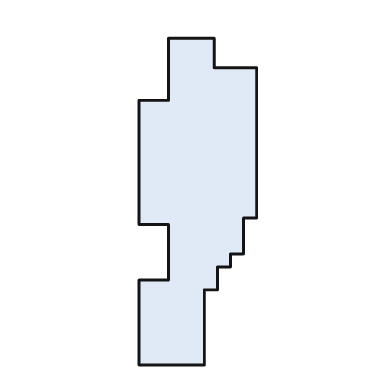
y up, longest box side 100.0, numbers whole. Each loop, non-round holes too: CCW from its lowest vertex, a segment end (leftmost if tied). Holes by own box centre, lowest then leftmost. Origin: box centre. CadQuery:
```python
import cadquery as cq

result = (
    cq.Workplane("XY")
    .moveTo(-18.0, -50.0)
    .lineTo(2.0, -50.0)
    .lineTo(2.0, -27.0)
    .lineTo(6.0, -27.0)
    .lineTo(6.0, -20.0)
    .lineTo(10.0, -20.0)
    .lineTo(10.0, -16.0)
    .lineTo(14.0, -16.0)
    .lineTo(14.0, -5.0)
    .lineTo(18.0, -5.0)
    .lineTo(18.0, 41.0)
    .lineTo(5.0, 41.0)
    .lineTo(5.0, 50.0)
    .lineTo(-9.0, 50.0)
    .lineTo(-9.0, 31.0)
    .lineTo(-18.0, 31.0)
    .lineTo(-18.0, -7.0)
    .lineTo(-9.0, -7.0)
    .lineTo(-9.0, -24.0)
    .lineTo(-18.0, -24.0)
    .close()
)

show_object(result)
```